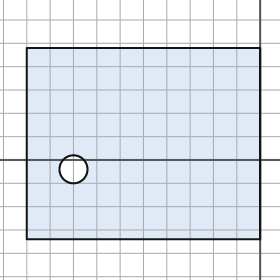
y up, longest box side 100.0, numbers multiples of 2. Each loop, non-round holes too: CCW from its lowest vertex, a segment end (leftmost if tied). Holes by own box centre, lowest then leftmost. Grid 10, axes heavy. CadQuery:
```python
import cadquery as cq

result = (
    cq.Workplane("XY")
    .moveTo(-100.0, -34.0)
    .lineTo(0.0, -34.0)
    .lineTo(0.0, 48.0)
    .lineTo(-100.0, 48.0)
    .close()
    .moveTo(-80.0, -4.0)
    .circle(6.0)
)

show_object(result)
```